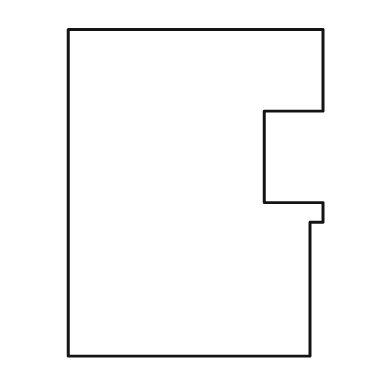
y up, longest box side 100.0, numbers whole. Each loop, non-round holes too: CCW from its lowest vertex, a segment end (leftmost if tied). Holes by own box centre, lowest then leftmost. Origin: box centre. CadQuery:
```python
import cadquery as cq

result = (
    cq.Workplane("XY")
    .moveTo(-39.0, -50.0)
    .lineTo(35.0, -50.0)
    .lineTo(35.0, -9.0)
    .lineTo(39.0, -9.0)
    .lineTo(39.0, -3.0)
    .lineTo(21.0, -3.0)
    .lineTo(21.0, 25.0)
    .lineTo(39.0, 25.0)
    .lineTo(39.0, 50.0)
    .lineTo(-39.0, 50.0)
    .close()
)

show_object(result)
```